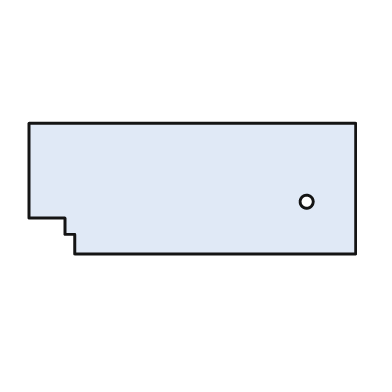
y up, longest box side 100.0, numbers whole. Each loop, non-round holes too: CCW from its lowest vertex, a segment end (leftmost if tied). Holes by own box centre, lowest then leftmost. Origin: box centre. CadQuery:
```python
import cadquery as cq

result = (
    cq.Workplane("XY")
    .moveTo(-36.0, -20.0)
    .lineTo(50.0, -20.0)
    .lineTo(50.0, 20.0)
    .lineTo(-50.0, 20.0)
    .lineTo(-50.0, -9.0)
    .lineTo(-39.0, -9.0)
    .lineTo(-39.0, -14.0)
    .lineTo(-36.0, -14.0)
    .close()
    .moveTo(35.0, -4.0)
    .circle(2.0)
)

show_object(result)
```